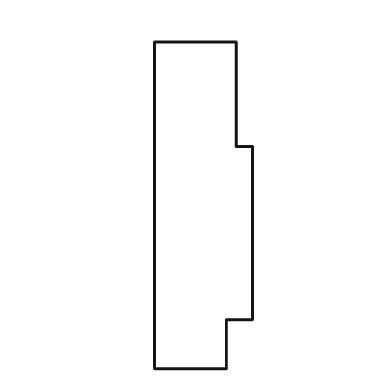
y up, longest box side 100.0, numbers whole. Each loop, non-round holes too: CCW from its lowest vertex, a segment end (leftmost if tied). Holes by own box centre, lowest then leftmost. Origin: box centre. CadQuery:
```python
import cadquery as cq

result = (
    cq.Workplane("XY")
    .moveTo(-15.0, -50.0)
    .lineTo(7.0, -50.0)
    .lineTo(7.0, -35.0)
    .lineTo(15.0, -35.0)
    .lineTo(15.0, 18.0)
    .lineTo(10.0, 18.0)
    .lineTo(10.0, 50.0)
    .lineTo(-15.0, 50.0)
    .close()
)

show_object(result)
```